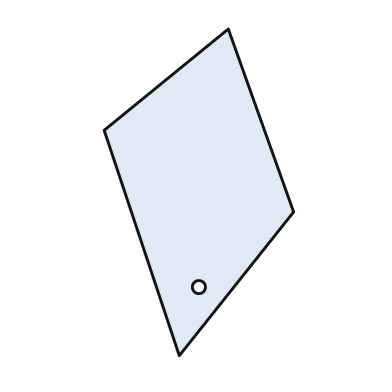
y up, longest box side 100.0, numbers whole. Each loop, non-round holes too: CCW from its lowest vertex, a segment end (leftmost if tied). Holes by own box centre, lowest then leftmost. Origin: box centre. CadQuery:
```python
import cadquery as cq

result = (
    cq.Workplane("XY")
    .moveTo(-6.0, -50.0)
    .lineTo(29.0, -6.0)
    .lineTo(9.0, 50.0)
    .lineTo(-29.0, 19.0)
    .close()
    .moveTo(0.0, -29.0)
    .circle(2.0)
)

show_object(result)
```